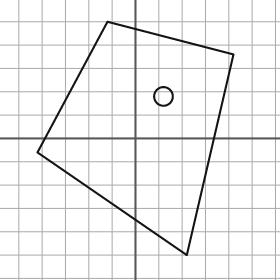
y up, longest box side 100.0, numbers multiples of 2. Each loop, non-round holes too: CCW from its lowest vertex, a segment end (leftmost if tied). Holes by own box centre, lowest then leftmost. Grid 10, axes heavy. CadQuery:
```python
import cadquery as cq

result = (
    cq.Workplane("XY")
    .moveTo(22.0, -50.0)
    .lineTo(42.0, 36.0)
    .lineTo(-12.0, 50.0)
    .lineTo(-42.0, -6.0)
    .close()
    .moveTo(12.0, 18.0)
    .circle(4.0)
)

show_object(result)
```